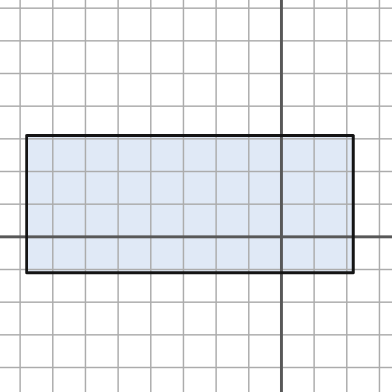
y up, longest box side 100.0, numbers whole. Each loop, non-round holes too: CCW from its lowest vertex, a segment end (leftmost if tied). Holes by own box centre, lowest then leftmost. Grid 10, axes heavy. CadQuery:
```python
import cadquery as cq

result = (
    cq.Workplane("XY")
    .moveTo(-78.0, -11.0)
    .lineTo(22.0, -11.0)
    .lineTo(22.0, 31.0)
    .lineTo(-78.0, 31.0)
    .close()
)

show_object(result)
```